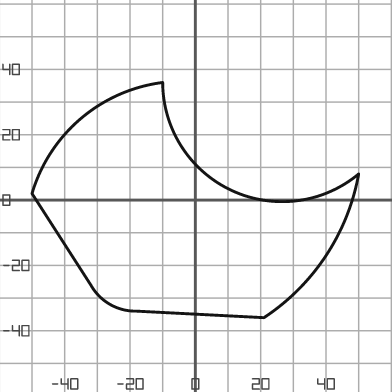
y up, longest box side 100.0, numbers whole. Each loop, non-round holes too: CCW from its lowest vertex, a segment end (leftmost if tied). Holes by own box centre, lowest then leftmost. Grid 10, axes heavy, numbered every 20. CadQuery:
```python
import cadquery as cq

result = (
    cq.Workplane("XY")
    .moveTo(21.0, -36.0)
    .threePointArc((40.0, -17.0), (50.0, 8.0))
    .threePointArc((11.0, 3.0), (-10.0, 36.0))
    .threePointArc((-35.0, 25.0), (-50.0, 2.0))
    .lineTo(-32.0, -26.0)
    .threePointArc((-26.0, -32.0), (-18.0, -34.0))
    .close()
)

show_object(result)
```